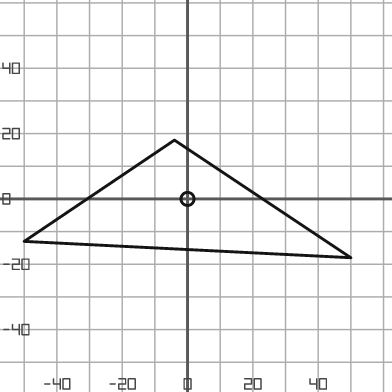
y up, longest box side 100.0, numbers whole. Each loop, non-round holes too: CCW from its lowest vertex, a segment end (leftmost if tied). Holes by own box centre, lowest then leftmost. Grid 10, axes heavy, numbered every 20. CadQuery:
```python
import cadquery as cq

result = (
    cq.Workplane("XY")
    .moveTo(50.0, -18.0)
    .lineTo(-4.0, 18.0)
    .lineTo(-50.0, -13.0)
    .close()
    .moveTo(0.0, 0.0)
    .circle(2.0)
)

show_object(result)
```